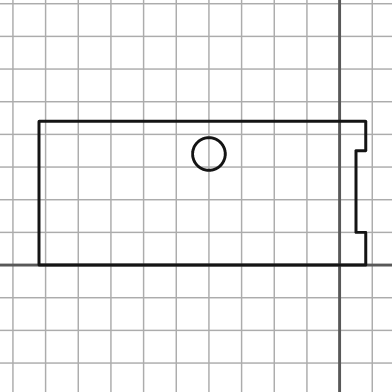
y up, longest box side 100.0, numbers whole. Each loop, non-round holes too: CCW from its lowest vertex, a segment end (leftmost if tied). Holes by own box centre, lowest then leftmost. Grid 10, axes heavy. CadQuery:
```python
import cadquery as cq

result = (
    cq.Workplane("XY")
    .moveTo(-92.0, 0.0)
    .lineTo(8.0, 0.0)
    .lineTo(8.0, 10.0)
    .lineTo(5.0, 10.0)
    .lineTo(5.0, 35.0)
    .lineTo(8.0, 35.0)
    .lineTo(8.0, 44.0)
    .lineTo(-92.0, 44.0)
    .close()
    .moveTo(-40.0, 34.0)
    .circle(5.0)
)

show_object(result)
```